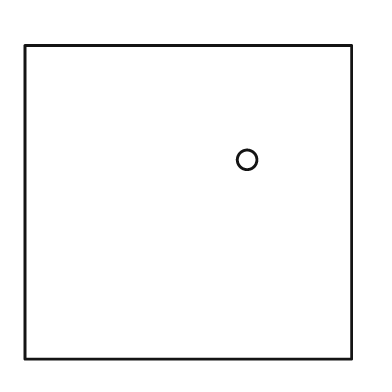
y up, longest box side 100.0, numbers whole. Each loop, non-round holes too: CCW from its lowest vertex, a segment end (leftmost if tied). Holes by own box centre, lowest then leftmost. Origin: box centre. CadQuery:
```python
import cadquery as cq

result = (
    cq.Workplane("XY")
    .moveTo(-50.0, -48.0)
    .lineTo(50.0, -48.0)
    .lineTo(50.0, 48.0)
    .lineTo(-50.0, 48.0)
    .close()
    .moveTo(18.0, 13.0)
    .circle(3.0)
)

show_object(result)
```